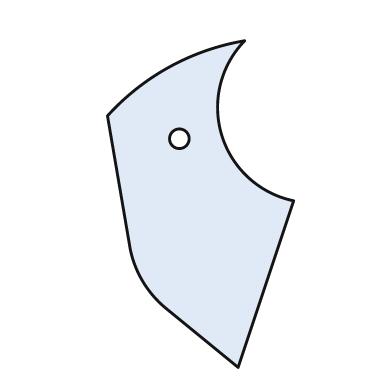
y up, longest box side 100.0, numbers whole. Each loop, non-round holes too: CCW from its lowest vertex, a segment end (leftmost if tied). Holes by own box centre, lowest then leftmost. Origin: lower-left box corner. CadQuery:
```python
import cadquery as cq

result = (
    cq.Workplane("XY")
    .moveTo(40.0, 0.0)
    .lineTo(57.0, 51.0)
    .threePointArc((35.0, 71.0), (42.0, 100.0))
    .threePointArc((19.0, 92.0), (0.0, 77.0))
    .lineTo(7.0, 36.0)
    .threePointArc((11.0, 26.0), (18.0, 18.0))
    .close()
    .moveTo(22.0, 70.0)
    .circle(3.0)
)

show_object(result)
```